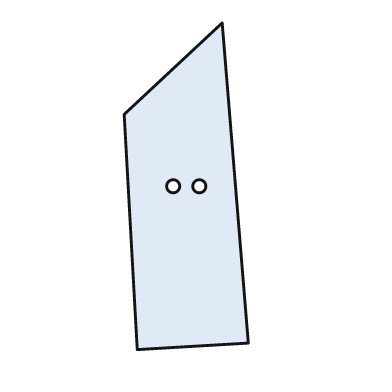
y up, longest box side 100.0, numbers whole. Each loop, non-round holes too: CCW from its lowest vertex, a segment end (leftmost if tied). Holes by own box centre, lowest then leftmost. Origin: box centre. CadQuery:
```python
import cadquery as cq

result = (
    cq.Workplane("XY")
    .moveTo(-15.0, -50.0)
    .lineTo(19.0, -48.0)
    .lineTo(11.0, 50.0)
    .lineTo(-19.0, 22.0)
    .close()
    .moveTo(-4.0, 0.0)
    .circle(2.0)
    .moveTo(4.0, 0.0)
    .circle(2.0)
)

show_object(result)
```